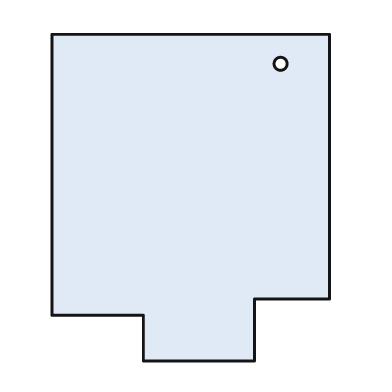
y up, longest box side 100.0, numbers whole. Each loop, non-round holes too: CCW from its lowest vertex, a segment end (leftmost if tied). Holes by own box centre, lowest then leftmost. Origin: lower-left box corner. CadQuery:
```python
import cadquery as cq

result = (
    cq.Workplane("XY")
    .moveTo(28.0, 0.0)
    .lineTo(62.0, 0.0)
    .lineTo(62.0, 19.0)
    .lineTo(85.0, 19.0)
    .lineTo(85.0, 100.0)
    .lineTo(0.0, 100.0)
    .lineTo(0.0, 14.0)
    .lineTo(28.0, 14.0)
    .close()
    .moveTo(70.0, 91.0)
    .circle(2.0)
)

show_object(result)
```